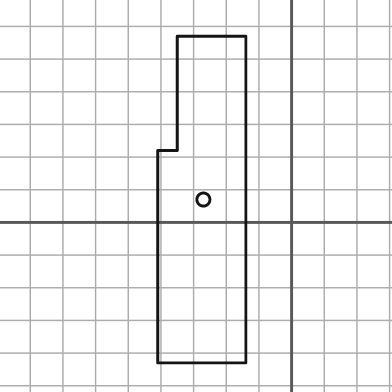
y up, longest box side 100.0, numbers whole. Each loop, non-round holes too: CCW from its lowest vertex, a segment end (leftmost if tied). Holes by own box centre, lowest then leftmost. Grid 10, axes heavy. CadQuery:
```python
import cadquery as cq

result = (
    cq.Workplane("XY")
    .moveTo(-41.0, -43.0)
    .lineTo(-14.0, -43.0)
    .lineTo(-14.0, 57.0)
    .lineTo(-35.0, 57.0)
    .lineTo(-35.0, 22.0)
    .lineTo(-41.0, 22.0)
    .close()
    .moveTo(-27.0, 7.0)
    .circle(2.0)
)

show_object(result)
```